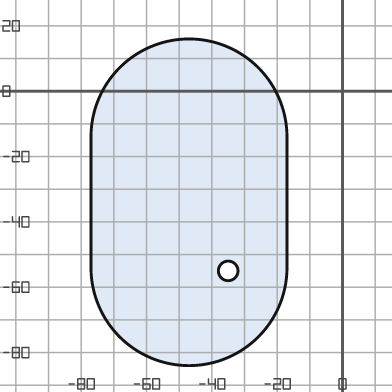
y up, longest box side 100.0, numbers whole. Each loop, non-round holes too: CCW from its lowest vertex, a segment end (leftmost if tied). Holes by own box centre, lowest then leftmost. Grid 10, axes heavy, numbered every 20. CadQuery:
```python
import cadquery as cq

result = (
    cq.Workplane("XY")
    .moveTo(-77.0, -54.0)
    .threePointArc((-47.0, -84.0), (-17.0, -54.0))
    .lineTo(-17.0, -14.0)
    .threePointArc((-47.0, 16.0), (-77.0, -14.0))
    .close()
    .moveTo(-35.0, -55.0)
    .circle(3.0)
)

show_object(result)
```